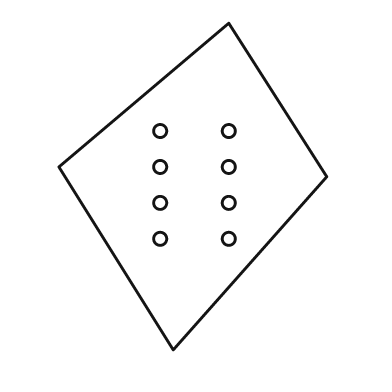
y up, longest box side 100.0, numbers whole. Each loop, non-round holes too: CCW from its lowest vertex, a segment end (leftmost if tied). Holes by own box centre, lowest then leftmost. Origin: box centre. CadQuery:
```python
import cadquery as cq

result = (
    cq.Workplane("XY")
    .moveTo(-6.0, -50.0)
    .lineTo(41.0, 3.0)
    .lineTo(11.0, 50.0)
    .lineTo(-41.0, 6.0)
    .close()
    .moveTo(-10.0, -16.0)
    .circle(2.0)
    .moveTo(11.0, -16.0)
    .circle(2.0)
    .moveTo(-10.0, -5.0)
    .circle(2.0)
    .moveTo(11.0, -5.0)
    .circle(2.0)
    .moveTo(-10.0, 6.0)
    .circle(2.0)
    .moveTo(11.0, 6.0)
    .circle(2.0)
    .moveTo(-10.0, 17.0)
    .circle(2.0)
    .moveTo(11.0, 17.0)
    .circle(2.0)
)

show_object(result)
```